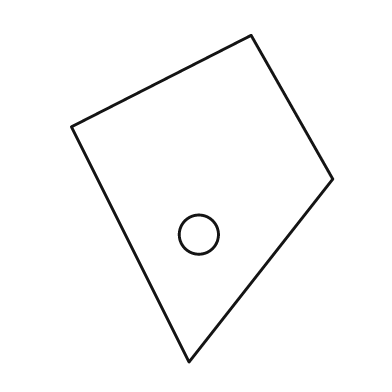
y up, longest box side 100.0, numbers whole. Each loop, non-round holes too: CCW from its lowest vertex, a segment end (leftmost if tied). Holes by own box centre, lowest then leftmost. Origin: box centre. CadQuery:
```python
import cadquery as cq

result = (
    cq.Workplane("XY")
    .moveTo(-4.0, -50.0)
    .lineTo(40.0, 6.0)
    .lineTo(15.0, 50.0)
    .lineTo(-40.0, 22.0)
    .close()
    .moveTo(-1.0, -11.0)
    .circle(6.0)
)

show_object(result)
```